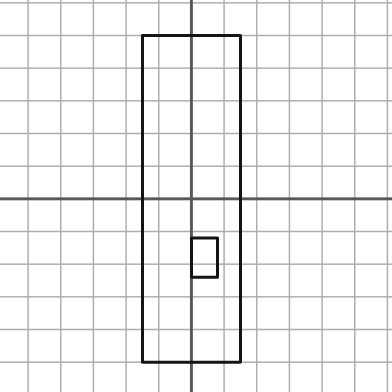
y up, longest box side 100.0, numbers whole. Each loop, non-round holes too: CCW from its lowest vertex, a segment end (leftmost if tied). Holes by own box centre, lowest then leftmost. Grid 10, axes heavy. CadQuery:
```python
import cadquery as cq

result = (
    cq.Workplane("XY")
    .moveTo(-15.0, -50.0)
    .lineTo(15.0, -50.0)
    .lineTo(15.0, 50.0)
    .lineTo(-15.0, 50.0)
    .close()
    .moveTo(0.0, -24.0)
    .lineTo(8.0, -24.0)
    .lineTo(8.0, -12.0)
    .lineTo(0.0, -12.0)
    .close()
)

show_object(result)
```